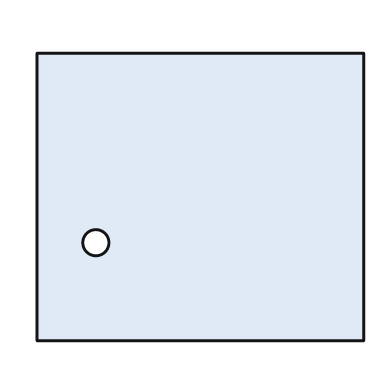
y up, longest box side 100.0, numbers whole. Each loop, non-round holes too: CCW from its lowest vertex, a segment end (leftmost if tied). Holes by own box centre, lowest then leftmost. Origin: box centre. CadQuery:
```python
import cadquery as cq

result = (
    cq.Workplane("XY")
    .moveTo(-50.0, -44.0)
    .lineTo(50.0, -44.0)
    .lineTo(50.0, 44.0)
    .lineTo(-50.0, 44.0)
    .close()
    .moveTo(-32.0, -14.0)
    .circle(4.0)
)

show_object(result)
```